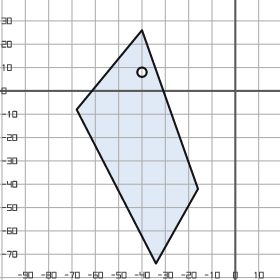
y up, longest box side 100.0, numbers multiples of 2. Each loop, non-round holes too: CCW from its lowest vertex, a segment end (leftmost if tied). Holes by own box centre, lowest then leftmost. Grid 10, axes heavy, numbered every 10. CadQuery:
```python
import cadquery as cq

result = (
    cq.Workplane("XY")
    .moveTo(-34.0, -74.0)
    .lineTo(-16.0, -42.0)
    .lineTo(-40.0, 26.0)
    .lineTo(-68.0, -8.0)
    .close()
    .moveTo(-40.0, 8.0)
    .circle(2.0)
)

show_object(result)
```